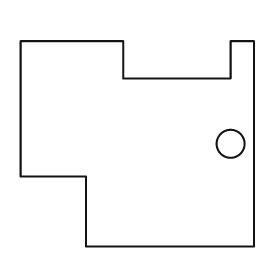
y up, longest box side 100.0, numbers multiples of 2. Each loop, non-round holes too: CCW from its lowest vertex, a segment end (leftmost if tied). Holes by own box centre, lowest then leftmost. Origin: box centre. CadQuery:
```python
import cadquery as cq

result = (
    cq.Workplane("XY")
    .moveTo(-22.0, -44.0)
    .lineTo(50.0, -44.0)
    .lineTo(50.0, 44.0)
    .lineTo(40.0, 44.0)
    .lineTo(40.0, 28.0)
    .lineTo(-6.0, 28.0)
    .lineTo(-6.0, 44.0)
    .lineTo(-50.0, 44.0)
    .lineTo(-50.0, -14.0)
    .lineTo(-22.0, -14.0)
    .close()
    .moveTo(40.0, 0.0)
    .circle(6.0)
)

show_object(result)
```